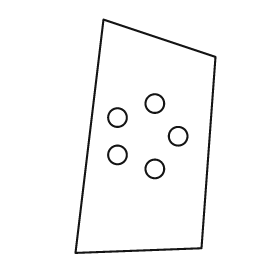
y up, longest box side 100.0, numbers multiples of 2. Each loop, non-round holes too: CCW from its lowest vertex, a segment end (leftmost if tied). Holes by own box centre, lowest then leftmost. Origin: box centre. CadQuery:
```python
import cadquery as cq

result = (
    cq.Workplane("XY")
    .moveTo(-30.0, -50.0)
    .lineTo(24.0, -48.0)
    .lineTo(30.0, 34.0)
    .lineTo(-18.0, 50.0)
    .close()
    .moveTo(4.0, -14.0)
    .circle(4.0)
    .moveTo(-12.0, -8.0)
    .circle(4.0)
    .moveTo(14.0, 0.0)
    .circle(4.0)
    .moveTo(-12.0, 8.0)
    .circle(4.0)
    .moveTo(4.0, 14.0)
    .circle(4.0)
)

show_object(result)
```